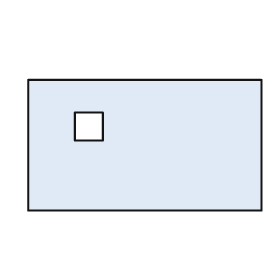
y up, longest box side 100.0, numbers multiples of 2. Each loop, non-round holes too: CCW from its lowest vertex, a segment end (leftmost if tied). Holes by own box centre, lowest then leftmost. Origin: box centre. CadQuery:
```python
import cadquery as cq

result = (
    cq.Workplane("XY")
    .moveTo(-50.0, -28.0)
    .lineTo(50.0, -28.0)
    .lineTo(50.0, 28.0)
    .lineTo(-50.0, 28.0)
    .close()
    .moveTo(-30.0, 2.0)
    .lineTo(-18.0, 2.0)
    .lineTo(-18.0, 14.0)
    .lineTo(-30.0, 14.0)
    .close()
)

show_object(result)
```